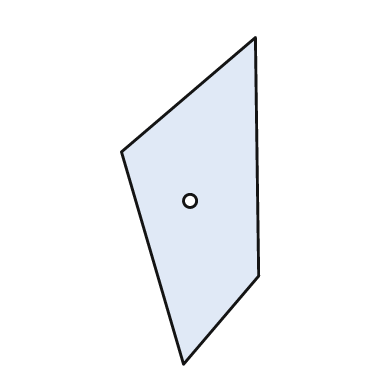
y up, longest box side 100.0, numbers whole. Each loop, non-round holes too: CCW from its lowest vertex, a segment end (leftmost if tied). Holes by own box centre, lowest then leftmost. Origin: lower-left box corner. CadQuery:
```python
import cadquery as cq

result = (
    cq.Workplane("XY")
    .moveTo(19.0, 0.0)
    .lineTo(42.0, 27.0)
    .lineTo(41.0, 100.0)
    .lineTo(0.0, 65.0)
    .close()
    .moveTo(21.0, 50.0)
    .circle(2.0)
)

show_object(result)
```